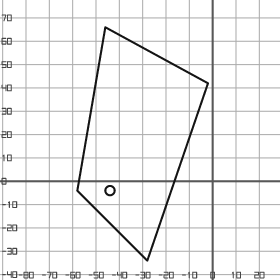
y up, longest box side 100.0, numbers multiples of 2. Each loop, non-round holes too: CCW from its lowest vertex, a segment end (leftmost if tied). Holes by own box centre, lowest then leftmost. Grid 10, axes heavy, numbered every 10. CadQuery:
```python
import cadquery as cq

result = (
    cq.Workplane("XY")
    .moveTo(-28.0, -34.0)
    .lineTo(-2.0, 42.0)
    .lineTo(-46.0, 66.0)
    .lineTo(-58.0, -4.0)
    .close()
    .moveTo(-44.0, -4.0)
    .circle(2.0)
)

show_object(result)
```